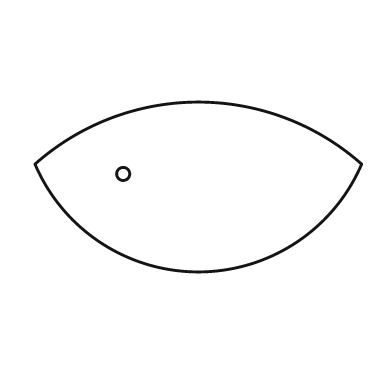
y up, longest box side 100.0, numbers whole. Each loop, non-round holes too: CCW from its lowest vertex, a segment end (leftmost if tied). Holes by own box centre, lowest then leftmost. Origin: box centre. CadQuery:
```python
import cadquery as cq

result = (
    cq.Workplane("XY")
    .moveTo(-50.0, 7.0)
    .threePointArc((0.0, -26.0), (50.0, 7.0))
    .threePointArc((0.0, 26.0), (-50.0, 7.0))
    .close()
    .moveTo(-23.0, 4.0)
    .circle(2.0)
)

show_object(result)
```